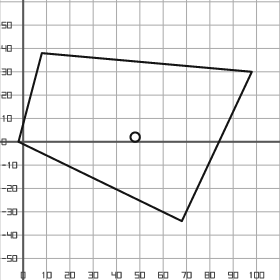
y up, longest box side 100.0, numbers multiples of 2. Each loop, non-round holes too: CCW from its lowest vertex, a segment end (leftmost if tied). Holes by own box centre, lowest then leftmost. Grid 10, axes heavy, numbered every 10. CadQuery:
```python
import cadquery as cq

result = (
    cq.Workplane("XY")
    .moveTo(68.0, -34.0)
    .lineTo(98.0, 30.0)
    .lineTo(8.0, 38.0)
    .lineTo(-2.0, 0.0)
    .close()
    .moveTo(48.0, 2.0)
    .circle(2.0)
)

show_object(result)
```